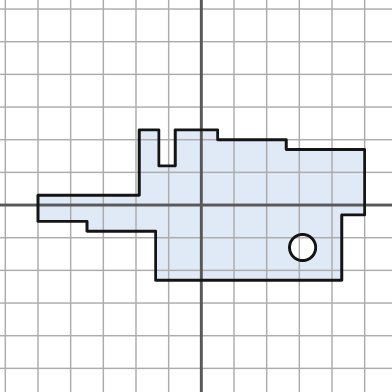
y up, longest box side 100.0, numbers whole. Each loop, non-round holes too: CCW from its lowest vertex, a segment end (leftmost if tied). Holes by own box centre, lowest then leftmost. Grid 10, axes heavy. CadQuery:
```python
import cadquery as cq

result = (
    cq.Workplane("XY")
    .moveTo(-14.0, -23.0)
    .lineTo(43.0, -23.0)
    .lineTo(43.0, -3.0)
    .lineTo(50.0, -3.0)
    .lineTo(50.0, 17.0)
    .lineTo(26.0, 17.0)
    .lineTo(26.0, 20.0)
    .lineTo(5.0, 20.0)
    .lineTo(5.0, 23.0)
    .lineTo(-8.0, 23.0)
    .lineTo(-8.0, 12.0)
    .lineTo(-13.0, 12.0)
    .lineTo(-13.0, 23.0)
    .lineTo(-19.0, 23.0)
    .lineTo(-19.0, 3.0)
    .lineTo(-50.0, 3.0)
    .lineTo(-50.0, -5.0)
    .lineTo(-35.0, -5.0)
    .lineTo(-35.0, -8.0)
    .lineTo(-14.0, -8.0)
    .close()
    .moveTo(31.0, -13.0)
    .circle(4.0)
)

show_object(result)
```